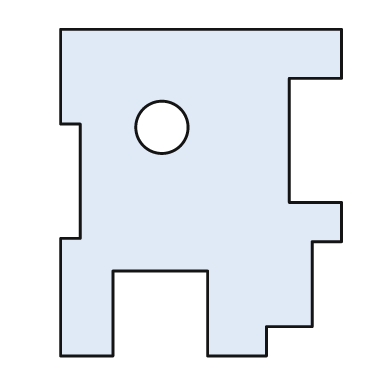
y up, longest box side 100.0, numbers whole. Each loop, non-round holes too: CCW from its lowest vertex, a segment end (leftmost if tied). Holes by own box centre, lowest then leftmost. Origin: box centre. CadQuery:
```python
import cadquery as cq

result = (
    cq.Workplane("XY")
    .moveTo(-43.0, -50.0)
    .lineTo(-27.0, -50.0)
    .lineTo(-27.0, -24.0)
    .lineTo(2.0, -24.0)
    .lineTo(2.0, -50.0)
    .lineTo(20.0, -50.0)
    .lineTo(20.0, -41.0)
    .lineTo(34.0, -41.0)
    .lineTo(34.0, -15.0)
    .lineTo(43.0, -15.0)
    .lineTo(43.0, -3.0)
    .lineTo(27.0, -3.0)
    .lineTo(27.0, 35.0)
    .lineTo(43.0, 35.0)
    .lineTo(43.0, 50.0)
    .lineTo(-43.0, 50.0)
    .lineTo(-43.0, 21.0)
    .lineTo(-37.0, 21.0)
    .lineTo(-37.0, -14.0)
    .lineTo(-43.0, -14.0)
    .close()
    .moveTo(-12.0, 20.0)
    .circle(8.0)
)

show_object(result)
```